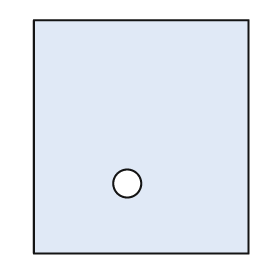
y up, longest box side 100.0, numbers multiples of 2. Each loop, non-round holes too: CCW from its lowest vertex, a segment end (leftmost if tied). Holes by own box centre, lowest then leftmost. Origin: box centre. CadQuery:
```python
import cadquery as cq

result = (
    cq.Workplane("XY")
    .moveTo(-46.0, -50.0)
    .lineTo(46.0, -50.0)
    .lineTo(46.0, 50.0)
    .lineTo(-46.0, 50.0)
    .close()
    .moveTo(-6.0, -20.0)
    .circle(6.0)
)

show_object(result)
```